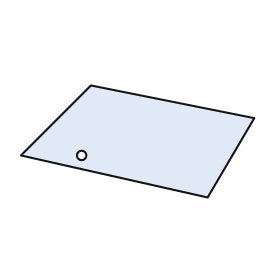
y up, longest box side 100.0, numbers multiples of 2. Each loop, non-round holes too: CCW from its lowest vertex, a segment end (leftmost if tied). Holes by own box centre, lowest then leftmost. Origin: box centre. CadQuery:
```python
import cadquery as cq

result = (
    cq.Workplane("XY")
    .moveTo(30.0, -24.0)
    .lineTo(50.0, 10.0)
    .lineTo(-20.0, 24.0)
    .lineTo(-50.0, -6.0)
    .close()
    .moveTo(-24.0, -6.0)
    .circle(2.0)
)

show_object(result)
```